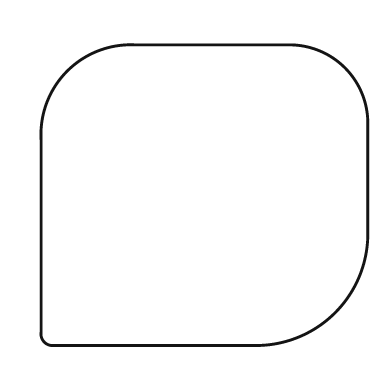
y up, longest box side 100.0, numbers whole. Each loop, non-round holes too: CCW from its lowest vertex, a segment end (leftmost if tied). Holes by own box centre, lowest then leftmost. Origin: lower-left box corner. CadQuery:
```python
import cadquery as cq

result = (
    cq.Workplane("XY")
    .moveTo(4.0, 0.0)
    .lineTo(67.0, 0.0)
    .threePointArc((90.0, 10.0), (100.0, 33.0))
    .lineTo(100.0, 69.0)
    .threePointArc((93.0, 85.0), (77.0, 92.0))
    .lineTo(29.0, 92.0)
    .threePointArc((8.0, 84.0), (0.0, 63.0))
    .lineTo(0.0, 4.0)
    .threePointArc((1.0, 1.0), (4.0, 0.0))
    .close()
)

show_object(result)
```